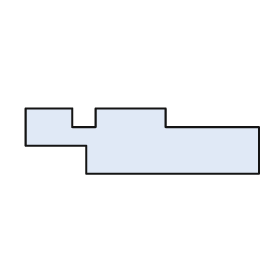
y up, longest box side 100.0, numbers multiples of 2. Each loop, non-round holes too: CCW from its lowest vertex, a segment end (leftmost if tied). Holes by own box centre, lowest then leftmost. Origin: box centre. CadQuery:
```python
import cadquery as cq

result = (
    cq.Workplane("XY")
    .moveTo(-24.0, -14.0)
    .lineTo(50.0, -14.0)
    .lineTo(50.0, 6.0)
    .lineTo(10.0, 6.0)
    .lineTo(10.0, 14.0)
    .lineTo(-20.0, 14.0)
    .lineTo(-20.0, 6.0)
    .lineTo(-30.0, 6.0)
    .lineTo(-30.0, 14.0)
    .lineTo(-50.0, 14.0)
    .lineTo(-50.0, -2.0)
    .lineTo(-24.0, -2.0)
    .close()
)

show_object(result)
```